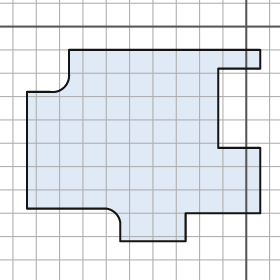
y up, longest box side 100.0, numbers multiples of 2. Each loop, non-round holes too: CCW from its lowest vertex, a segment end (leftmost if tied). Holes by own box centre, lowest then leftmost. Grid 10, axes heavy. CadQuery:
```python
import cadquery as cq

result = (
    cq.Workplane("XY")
    .moveTo(-54.0, -92.0)
    .lineTo(-26.0, -92.0)
    .lineTo(-26.0, -80.0)
    .lineTo(6.0, -80.0)
    .lineTo(6.0, -52.0)
    .lineTo(-12.0, -52.0)
    .lineTo(-12.0, -18.0)
    .lineTo(6.0, -18.0)
    .lineTo(6.0, -10.0)
    .lineTo(-76.0, -10.0)
    .lineTo(-76.0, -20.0)
    .threePointArc((-78.0, -26.0), (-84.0, -28.0))
    .lineTo(-94.0, -28.0)
    .lineTo(-94.0, -78.0)
    .lineTo(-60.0, -78.0)
    .threePointArc((-56.0, -80.0), (-54.0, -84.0))
    .close()
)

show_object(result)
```